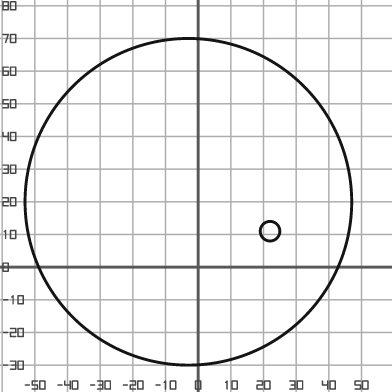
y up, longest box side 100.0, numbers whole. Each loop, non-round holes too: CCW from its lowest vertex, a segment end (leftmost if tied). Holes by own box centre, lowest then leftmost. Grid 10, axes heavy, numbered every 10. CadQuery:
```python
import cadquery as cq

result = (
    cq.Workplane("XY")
    .moveTo(-3.0, 20.0)
    .circle(50.0)
    .moveTo(22.0, 11.0)
    .circle(3.0)
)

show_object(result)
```